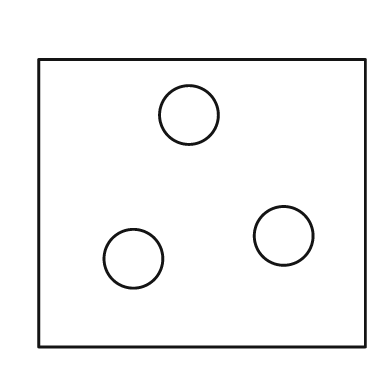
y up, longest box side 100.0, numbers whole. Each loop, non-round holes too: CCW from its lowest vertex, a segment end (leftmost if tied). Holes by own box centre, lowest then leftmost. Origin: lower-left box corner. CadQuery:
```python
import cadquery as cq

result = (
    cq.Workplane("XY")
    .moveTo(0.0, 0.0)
    .lineTo(100.0, 0.0)
    .lineTo(100.0, 88.0)
    .lineTo(0.0, 88.0)
    .close()
    .moveTo(29.0, 27.0)
    .circle(9.0)
    .moveTo(75.0, 34.0)
    .circle(9.0)
    .moveTo(46.0, 71.0)
    .circle(9.0)
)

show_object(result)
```